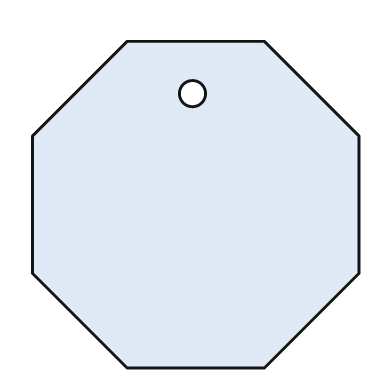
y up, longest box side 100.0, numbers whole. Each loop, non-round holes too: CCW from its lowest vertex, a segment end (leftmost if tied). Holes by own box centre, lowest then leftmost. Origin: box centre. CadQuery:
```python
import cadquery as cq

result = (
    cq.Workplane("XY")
    .moveTo(-21.0, -50.0)
    .lineTo(21.0, -50.0)
    .lineTo(50.0, -21.0)
    .lineTo(50.0, 21.0)
    .lineTo(21.0, 50.0)
    .lineTo(-21.0, 50.0)
    .lineTo(-50.0, 21.0)
    .lineTo(-50.0, -21.0)
    .close()
    .moveTo(-1.0, 34.0)
    .circle(4.0)
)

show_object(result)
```